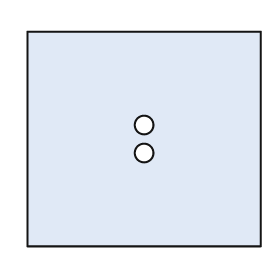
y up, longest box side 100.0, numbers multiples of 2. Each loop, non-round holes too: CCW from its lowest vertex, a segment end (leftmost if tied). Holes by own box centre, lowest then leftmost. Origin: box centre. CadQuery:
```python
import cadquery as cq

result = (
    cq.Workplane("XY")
    .moveTo(-50.0, -46.0)
    .lineTo(50.0, -46.0)
    .lineTo(50.0, 46.0)
    .lineTo(-50.0, 46.0)
    .close()
    .moveTo(0.0, -6.0)
    .circle(4.0)
    .moveTo(0.0, 6.0)
    .circle(4.0)
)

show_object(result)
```